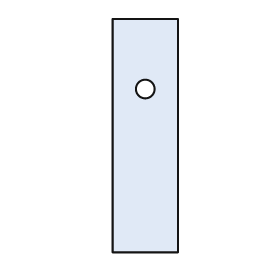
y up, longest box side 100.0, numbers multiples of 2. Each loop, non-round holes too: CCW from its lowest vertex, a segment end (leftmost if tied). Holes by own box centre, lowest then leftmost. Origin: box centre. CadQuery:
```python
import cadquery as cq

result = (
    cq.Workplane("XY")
    .moveTo(-14.0, -50.0)
    .lineTo(14.0, -50.0)
    .lineTo(14.0, 50.0)
    .lineTo(-14.0, 50.0)
    .close()
    .moveTo(0.0, 20.0)
    .circle(4.0)
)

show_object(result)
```